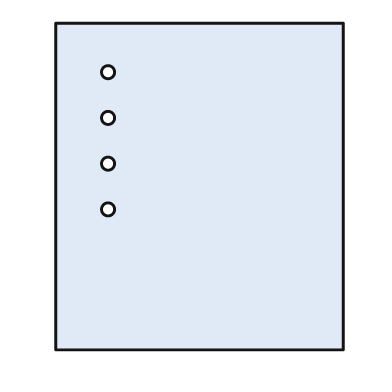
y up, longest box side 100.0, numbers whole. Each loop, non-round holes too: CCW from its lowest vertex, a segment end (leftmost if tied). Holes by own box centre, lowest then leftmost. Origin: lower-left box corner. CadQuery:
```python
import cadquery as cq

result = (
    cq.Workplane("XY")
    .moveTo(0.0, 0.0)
    .lineTo(88.0, 0.0)
    .lineTo(88.0, 100.0)
    .lineTo(0.0, 100.0)
    .close()
    .moveTo(16.0, 43.0)
    .circle(2.0)
    .moveTo(16.0, 57.0)
    .circle(2.0)
    .moveTo(16.0, 71.0)
    .circle(2.0)
    .moveTo(16.0, 85.0)
    .circle(2.0)
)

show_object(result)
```